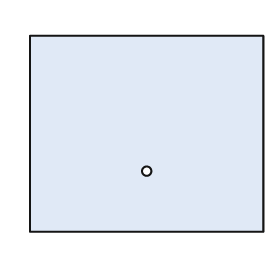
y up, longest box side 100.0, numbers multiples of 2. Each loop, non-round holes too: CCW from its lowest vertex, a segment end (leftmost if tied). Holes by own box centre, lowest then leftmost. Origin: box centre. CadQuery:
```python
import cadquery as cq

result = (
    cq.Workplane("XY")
    .moveTo(-50.0, -42.0)
    .lineTo(50.0, -42.0)
    .lineTo(50.0, 42.0)
    .lineTo(-50.0, 42.0)
    .close()
    .moveTo(0.0, -16.0)
    .circle(2.0)
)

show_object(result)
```